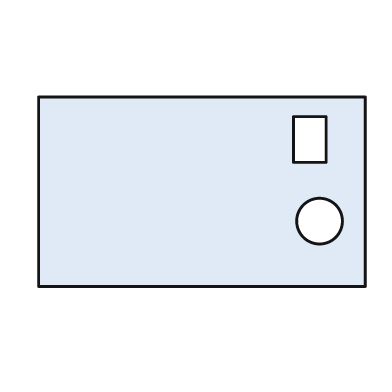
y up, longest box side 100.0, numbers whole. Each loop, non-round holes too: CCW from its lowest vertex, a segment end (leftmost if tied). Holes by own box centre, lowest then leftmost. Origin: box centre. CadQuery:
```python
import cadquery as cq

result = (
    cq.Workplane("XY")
    .moveTo(-50.0, -29.0)
    .lineTo(50.0, -29.0)
    .lineTo(50.0, 29.0)
    .lineTo(-50.0, 29.0)
    .close()
    .moveTo(36.0, -9.0)
    .circle(7.0)
    .moveTo(28.0, 9.0)
    .lineTo(38.0, 9.0)
    .lineTo(38.0, 23.0)
    .lineTo(28.0, 23.0)
    .close()
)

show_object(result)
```